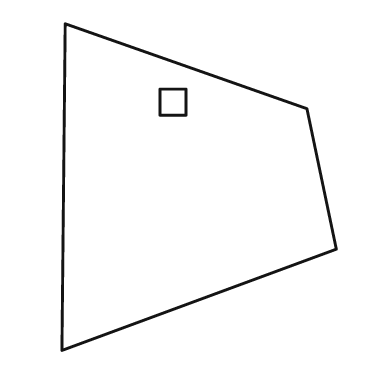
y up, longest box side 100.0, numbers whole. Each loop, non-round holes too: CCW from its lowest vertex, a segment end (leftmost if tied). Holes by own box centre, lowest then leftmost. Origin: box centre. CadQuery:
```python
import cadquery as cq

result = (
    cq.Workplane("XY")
    .moveTo(-42.0, -50.0)
    .lineTo(42.0, -19.0)
    .lineTo(33.0, 24.0)
    .lineTo(-41.0, 50.0)
    .close()
    .moveTo(-12.0, 22.0)
    .lineTo(-4.0, 22.0)
    .lineTo(-4.0, 30.0)
    .lineTo(-12.0, 30.0)
    .close()
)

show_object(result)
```